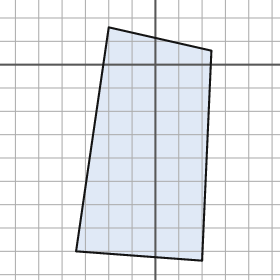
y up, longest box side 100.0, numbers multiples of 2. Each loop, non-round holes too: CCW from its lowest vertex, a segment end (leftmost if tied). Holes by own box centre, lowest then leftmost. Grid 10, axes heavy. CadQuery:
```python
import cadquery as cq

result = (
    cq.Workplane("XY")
    .moveTo(20.0, -84.0)
    .lineTo(24.0, 6.0)
    .lineTo(-20.0, 16.0)
    .lineTo(-34.0, -80.0)
    .close()
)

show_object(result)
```